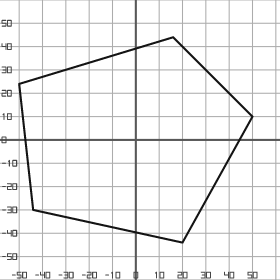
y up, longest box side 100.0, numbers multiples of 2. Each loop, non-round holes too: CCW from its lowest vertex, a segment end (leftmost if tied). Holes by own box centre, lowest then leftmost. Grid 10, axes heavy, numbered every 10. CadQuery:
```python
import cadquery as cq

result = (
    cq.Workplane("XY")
    .moveTo(20.0, -44.0)
    .lineTo(50.0, 10.0)
    .lineTo(16.0, 44.0)
    .lineTo(-50.0, 24.0)
    .lineTo(-44.0, -30.0)
    .close()
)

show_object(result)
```